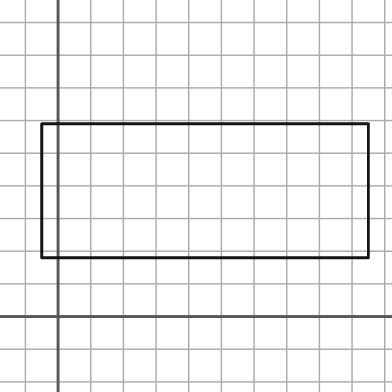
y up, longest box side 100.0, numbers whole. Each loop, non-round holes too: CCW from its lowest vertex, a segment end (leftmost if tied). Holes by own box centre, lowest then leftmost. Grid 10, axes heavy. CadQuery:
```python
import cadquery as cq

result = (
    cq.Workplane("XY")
    .moveTo(-5.0, 18.0)
    .lineTo(95.0, 18.0)
    .lineTo(95.0, 59.0)
    .lineTo(-5.0, 59.0)
    .close()
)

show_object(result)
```